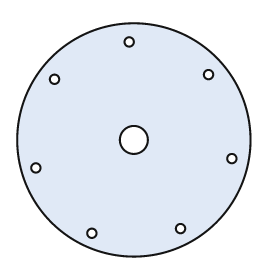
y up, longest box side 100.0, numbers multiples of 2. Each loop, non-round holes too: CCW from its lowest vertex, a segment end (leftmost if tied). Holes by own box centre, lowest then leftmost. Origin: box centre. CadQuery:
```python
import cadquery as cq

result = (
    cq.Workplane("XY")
    .moveTo(0.0, 0.0)
    .circle(50.0)
    .moveTo(-18.0, -40.0)
    .circle(2.0)
    .moveTo(20.0, -38.0)
    .circle(2.0)
    .moveTo(-42.0, -12.0)
    .circle(2.0)
    .moveTo(42.0, -8.0)
    .circle(2.0)
    .moveTo(0.0, 0.0)
    .circle(6.0)
    .moveTo(-34.0, 26.0)
    .circle(2.0)
    .moveTo(32.0, 28.0)
    .circle(2.0)
    .moveTo(-2.0, 42.0)
    .circle(2.0)
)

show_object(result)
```